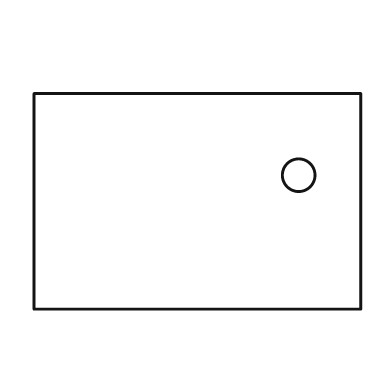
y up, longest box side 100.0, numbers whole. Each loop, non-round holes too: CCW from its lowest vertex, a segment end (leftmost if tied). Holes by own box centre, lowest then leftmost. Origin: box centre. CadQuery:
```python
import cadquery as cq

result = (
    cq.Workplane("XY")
    .moveTo(-50.0, -33.0)
    .lineTo(50.0, -33.0)
    .lineTo(50.0, 33.0)
    .lineTo(-50.0, 33.0)
    .close()
    .moveTo(31.0, 8.0)
    .circle(5.0)
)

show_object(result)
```